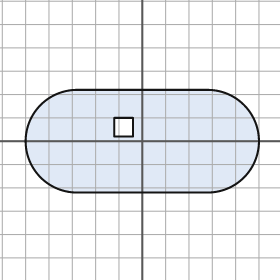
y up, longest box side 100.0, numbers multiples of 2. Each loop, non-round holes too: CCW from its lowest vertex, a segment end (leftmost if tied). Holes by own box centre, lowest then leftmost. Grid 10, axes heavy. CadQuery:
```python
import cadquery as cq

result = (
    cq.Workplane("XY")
    .moveTo(-28.0, -22.0)
    .lineTo(28.0, -22.0)
    .threePointArc((50.0, 0.0), (28.0, 22.0))
    .lineTo(-28.0, 22.0)
    .threePointArc((-50.0, 0.0), (-28.0, -22.0))
    .close()
    .moveTo(-12.0, 2.0)
    .lineTo(-4.0, 2.0)
    .lineTo(-4.0, 10.0)
    .lineTo(-12.0, 10.0)
    .close()
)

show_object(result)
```